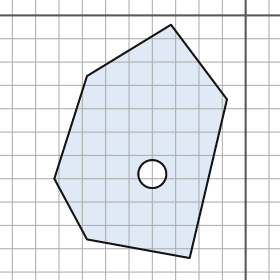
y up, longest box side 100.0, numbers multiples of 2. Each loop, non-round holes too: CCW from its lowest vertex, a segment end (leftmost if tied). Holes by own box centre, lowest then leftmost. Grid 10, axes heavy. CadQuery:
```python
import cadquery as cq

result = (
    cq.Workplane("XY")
    .moveTo(-24.0, -104.0)
    .lineTo(-8.0, -36.0)
    .lineTo(-32.0, -4.0)
    .lineTo(-68.0, -26.0)
    .lineTo(-82.0, -70.0)
    .lineTo(-68.0, -96.0)
    .close()
    .moveTo(-40.0, -68.0)
    .circle(6.0)
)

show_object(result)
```